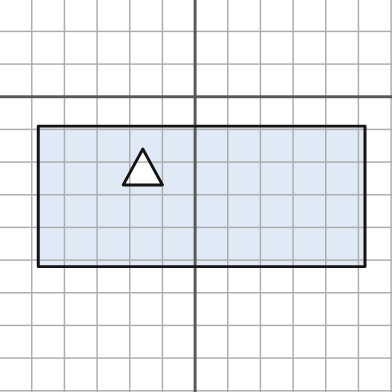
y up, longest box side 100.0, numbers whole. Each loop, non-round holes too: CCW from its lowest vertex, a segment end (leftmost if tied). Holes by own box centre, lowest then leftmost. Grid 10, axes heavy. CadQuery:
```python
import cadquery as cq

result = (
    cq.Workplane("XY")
    .moveTo(-48.0, -52.0)
    .lineTo(52.0, -52.0)
    .lineTo(52.0, -9.0)
    .lineTo(-48.0, -9.0)
    .close()
    .moveTo(-22.0, -27.0)
    .lineTo(-10.0, -27.0)
    .lineTo(-16.0, -16.0)
    .close()
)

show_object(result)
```